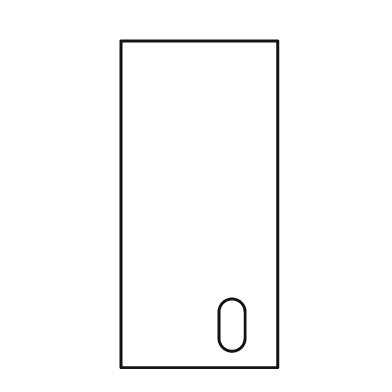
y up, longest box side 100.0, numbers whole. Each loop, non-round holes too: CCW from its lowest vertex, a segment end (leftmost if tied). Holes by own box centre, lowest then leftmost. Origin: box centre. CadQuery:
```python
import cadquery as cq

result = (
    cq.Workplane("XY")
    .moveTo(-24.0, -50.0)
    .lineTo(24.0, -50.0)
    .lineTo(24.0, 50.0)
    .lineTo(-24.0, 50.0)
    .close()
    .moveTo(6.0, -41.0)
    .threePointArc((10.0, -45.0), (14.0, -41.0))
    .lineTo(14.0, -33.0)
    .threePointArc((10.0, -29.0), (6.0, -33.0))
    .close()
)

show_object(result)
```